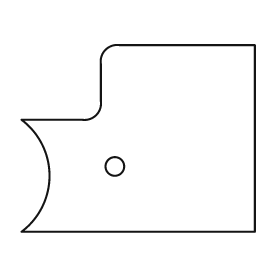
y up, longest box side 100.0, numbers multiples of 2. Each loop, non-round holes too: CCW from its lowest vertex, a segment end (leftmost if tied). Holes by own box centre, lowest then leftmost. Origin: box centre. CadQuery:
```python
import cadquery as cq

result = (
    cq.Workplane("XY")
    .moveTo(-50.0, -40.0)
    .lineTo(50.0, -40.0)
    .lineTo(50.0, 40.0)
    .lineTo(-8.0, 40.0)
    .threePointArc((-14.0, 38.0), (-16.0, 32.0))
    .lineTo(-16.0, 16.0)
    .threePointArc((-18.0, 10.0), (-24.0, 8.0))
    .lineTo(-50.0, 8.0)
    .threePointArc((-38.0, -16.0), (-50.0, -40.0))
    .close()
    .moveTo(-10.0, -12.0)
    .circle(4.0)
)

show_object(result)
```